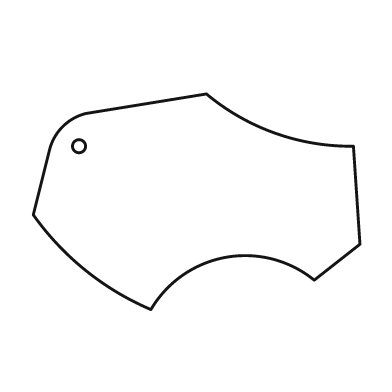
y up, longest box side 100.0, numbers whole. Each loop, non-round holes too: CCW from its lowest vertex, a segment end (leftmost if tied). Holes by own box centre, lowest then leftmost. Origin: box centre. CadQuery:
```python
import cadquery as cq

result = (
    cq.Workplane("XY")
    .moveTo(-14.0, -33.0)
    .threePointArc((9.0, -17.0), (36.0, -24.0))
    .lineTo(50.0, -13.0)
    .lineTo(48.0, 17.0)
    .threePointArc((24.0, 21.0), (3.0, 33.0))
    .lineTo(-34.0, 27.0)
    .threePointArc((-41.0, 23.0), (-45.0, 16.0))
    .lineTo(-50.0, -4.0)
    .threePointArc((-34.0, -21.0), (-14.0, -33.0))
    .close()
    .moveTo(-36.0, 17.0)
    .circle(2.0)
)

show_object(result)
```